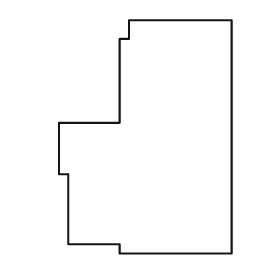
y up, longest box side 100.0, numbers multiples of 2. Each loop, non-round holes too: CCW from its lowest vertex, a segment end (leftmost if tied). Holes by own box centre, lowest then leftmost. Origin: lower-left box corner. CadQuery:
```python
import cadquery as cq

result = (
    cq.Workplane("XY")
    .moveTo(26.0, 0.0)
    .lineTo(74.0, 0.0)
    .lineTo(74.0, 100.0)
    .lineTo(30.0, 100.0)
    .lineTo(30.0, 92.0)
    .lineTo(26.0, 92.0)
    .lineTo(26.0, 56.0)
    .lineTo(0.0, 56.0)
    .lineTo(0.0, 34.0)
    .lineTo(4.0, 34.0)
    .lineTo(4.0, 4.0)
    .lineTo(26.0, 4.0)
    .close()
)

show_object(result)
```